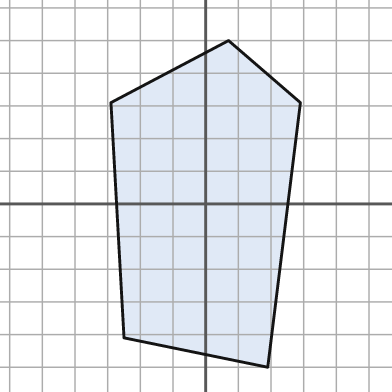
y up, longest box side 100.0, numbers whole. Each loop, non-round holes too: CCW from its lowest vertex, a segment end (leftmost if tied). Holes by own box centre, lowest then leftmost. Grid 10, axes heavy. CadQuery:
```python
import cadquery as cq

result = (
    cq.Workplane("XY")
    .moveTo(19.0, -50.0)
    .lineTo(29.0, 31.0)
    .lineTo(7.0, 50.0)
    .lineTo(-29.0, 31.0)
    .lineTo(-25.0, -41.0)
    .close()
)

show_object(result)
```